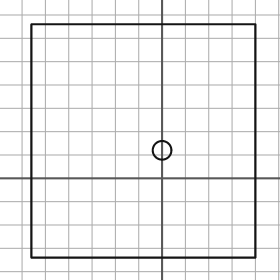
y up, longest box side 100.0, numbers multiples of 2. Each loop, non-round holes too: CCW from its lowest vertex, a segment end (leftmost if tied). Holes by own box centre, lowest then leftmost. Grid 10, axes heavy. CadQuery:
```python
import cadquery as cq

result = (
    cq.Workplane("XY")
    .moveTo(-56.0, -34.0)
    .lineTo(40.0, -34.0)
    .lineTo(40.0, 66.0)
    .lineTo(-56.0, 66.0)
    .close()
    .moveTo(0.0, 12.0)
    .circle(4.0)
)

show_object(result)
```